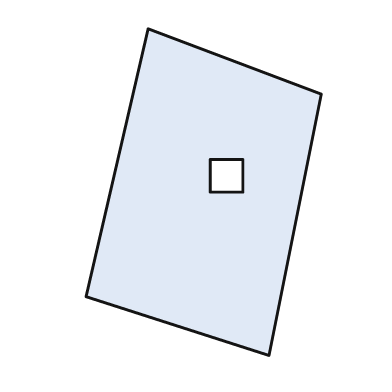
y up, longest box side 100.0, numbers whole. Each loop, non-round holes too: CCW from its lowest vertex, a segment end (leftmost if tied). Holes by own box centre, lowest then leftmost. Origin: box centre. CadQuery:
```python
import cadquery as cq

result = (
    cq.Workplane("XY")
    .moveTo(20.0, -50.0)
    .lineTo(36.0, 30.0)
    .lineTo(-17.0, 50.0)
    .lineTo(-36.0, -32.0)
    .close()
    .moveTo(2.0, 0.0)
    .lineTo(12.0, 0.0)
    .lineTo(12.0, 10.0)
    .lineTo(2.0, 10.0)
    .close()
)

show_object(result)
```